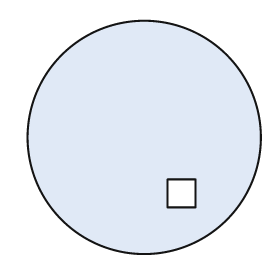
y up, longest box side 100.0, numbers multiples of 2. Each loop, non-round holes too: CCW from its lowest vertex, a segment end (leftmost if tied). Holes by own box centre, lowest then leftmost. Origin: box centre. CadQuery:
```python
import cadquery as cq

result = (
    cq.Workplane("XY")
    .moveTo(0.0, 0.0)
    .circle(50.0)
    .moveTo(10.0, -30.0)
    .lineTo(22.0, -30.0)
    .lineTo(22.0, -18.0)
    .lineTo(10.0, -18.0)
    .close()
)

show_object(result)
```